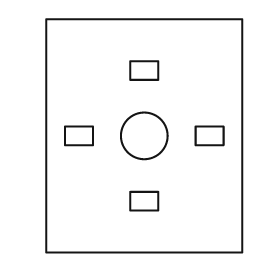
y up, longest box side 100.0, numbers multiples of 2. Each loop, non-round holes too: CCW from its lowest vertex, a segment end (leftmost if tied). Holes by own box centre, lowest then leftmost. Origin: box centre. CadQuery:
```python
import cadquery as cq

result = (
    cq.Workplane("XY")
    .moveTo(-42.0, -50.0)
    .lineTo(42.0, -50.0)
    .lineTo(42.0, 50.0)
    .lineTo(-42.0, 50.0)
    .close()
    .moveTo(-6.0, -32.0)
    .lineTo(6.0, -32.0)
    .lineTo(6.0, -24.0)
    .lineTo(-6.0, -24.0)
    .close()
    .moveTo(-34.0, -4.0)
    .lineTo(-22.0, -4.0)
    .lineTo(-22.0, 4.0)
    .lineTo(-34.0, 4.0)
    .close()
    .moveTo(0.0, 0.0)
    .circle(10.0)
    .moveTo(22.0, -4.0)
    .lineTo(34.0, -4.0)
    .lineTo(34.0, 4.0)
    .lineTo(22.0, 4.0)
    .close()
    .moveTo(-6.0, 24.0)
    .lineTo(6.0, 24.0)
    .lineTo(6.0, 32.0)
    .lineTo(-6.0, 32.0)
    .close()
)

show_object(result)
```